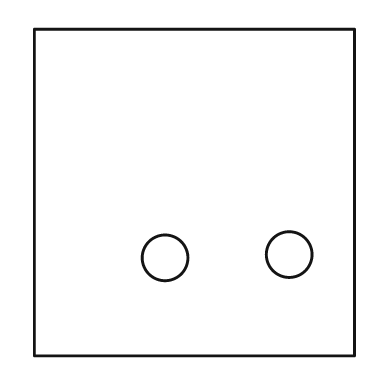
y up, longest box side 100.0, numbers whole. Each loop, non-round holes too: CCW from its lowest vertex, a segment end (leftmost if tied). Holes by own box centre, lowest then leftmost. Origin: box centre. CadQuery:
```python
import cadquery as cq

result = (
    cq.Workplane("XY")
    .moveTo(-49.0, -50.0)
    .lineTo(49.0, -50.0)
    .lineTo(49.0, 50.0)
    .lineTo(-49.0, 50.0)
    .close()
    .moveTo(-9.0, -20.0)
    .circle(7.0)
    .moveTo(29.0, -19.0)
    .circle(7.0)
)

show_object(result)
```